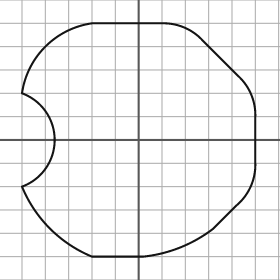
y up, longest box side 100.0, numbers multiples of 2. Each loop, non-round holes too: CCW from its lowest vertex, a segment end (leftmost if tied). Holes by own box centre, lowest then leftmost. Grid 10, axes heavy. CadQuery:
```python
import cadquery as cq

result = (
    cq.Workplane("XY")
    .moveTo(-20.0, -50.0)
    .lineTo(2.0, -50.0)
    .threePointArc((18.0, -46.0), (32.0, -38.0))
    .lineTo(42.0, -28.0)
    .threePointArc((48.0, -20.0), (50.0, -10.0))
    .lineTo(50.0, 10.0)
    .threePointArc((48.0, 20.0), (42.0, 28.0))
    .lineTo(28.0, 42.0)
    .threePointArc((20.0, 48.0), (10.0, 50.0))
    .lineTo(-20.0, 50.0)
    .threePointArc((-40.0, 40.0), (-50.0, 20.0))
    .threePointArc((-36.0, 0.0), (-50.0, -20.0))
    .threePointArc((-38.0, -38.0), (-20.0, -50.0))
    .close()
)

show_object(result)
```